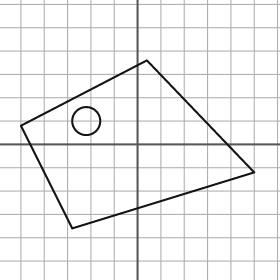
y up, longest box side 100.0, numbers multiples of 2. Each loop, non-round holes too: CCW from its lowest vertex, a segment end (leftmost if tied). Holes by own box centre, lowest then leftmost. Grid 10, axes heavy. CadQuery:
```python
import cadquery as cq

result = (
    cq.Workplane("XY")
    .moveTo(-28.0, -36.0)
    .lineTo(50.0, -12.0)
    .lineTo(4.0, 36.0)
    .lineTo(-50.0, 8.0)
    .close()
    .moveTo(-22.0, 10.0)
    .circle(6.0)
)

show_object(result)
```